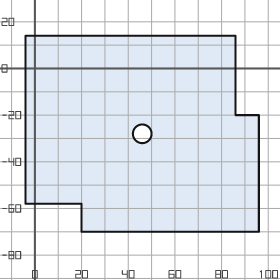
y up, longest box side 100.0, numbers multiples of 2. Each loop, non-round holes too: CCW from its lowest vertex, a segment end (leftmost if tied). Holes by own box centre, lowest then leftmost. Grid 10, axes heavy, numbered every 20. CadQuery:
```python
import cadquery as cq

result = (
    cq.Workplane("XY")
    .moveTo(20.0, -70.0)
    .lineTo(96.0, -70.0)
    .lineTo(96.0, -20.0)
    .lineTo(86.0, -20.0)
    .lineTo(86.0, 14.0)
    .lineTo(-4.0, 14.0)
    .lineTo(-4.0, -58.0)
    .lineTo(20.0, -58.0)
    .close()
    .moveTo(46.0, -28.0)
    .circle(4.0)
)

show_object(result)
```